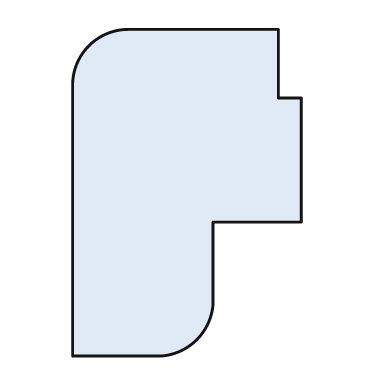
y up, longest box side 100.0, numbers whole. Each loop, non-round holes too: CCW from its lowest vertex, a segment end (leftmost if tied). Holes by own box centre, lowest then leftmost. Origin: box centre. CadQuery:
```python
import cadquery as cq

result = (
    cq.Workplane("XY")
    .moveTo(-35.0, -50.0)
    .lineTo(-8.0, -50.0)
    .threePointArc((3.0, -45.0), (8.0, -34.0))
    .lineTo(8.0, -9.0)
    .lineTo(35.0, -9.0)
    .lineTo(35.0, 29.0)
    .lineTo(28.0, 29.0)
    .lineTo(28.0, 50.0)
    .lineTo(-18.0, 50.0)
    .threePointArc((-30.0, 45.0), (-35.0, 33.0))
    .close()
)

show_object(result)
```